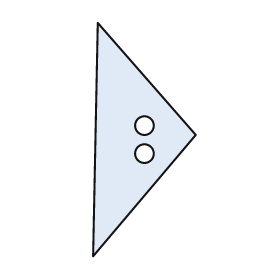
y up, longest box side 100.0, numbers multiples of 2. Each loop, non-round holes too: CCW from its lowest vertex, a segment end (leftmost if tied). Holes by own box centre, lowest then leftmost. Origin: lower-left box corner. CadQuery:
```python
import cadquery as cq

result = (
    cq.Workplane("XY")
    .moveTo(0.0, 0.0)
    .lineTo(44.0, 52.0)
    .lineTo(2.0, 100.0)
    .close()
    .moveTo(22.0, 44.0)
    .circle(4.0)
    .moveTo(22.0, 56.0)
    .circle(4.0)
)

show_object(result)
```